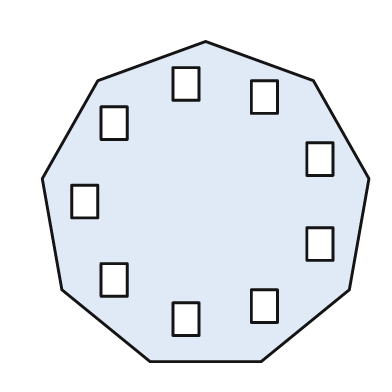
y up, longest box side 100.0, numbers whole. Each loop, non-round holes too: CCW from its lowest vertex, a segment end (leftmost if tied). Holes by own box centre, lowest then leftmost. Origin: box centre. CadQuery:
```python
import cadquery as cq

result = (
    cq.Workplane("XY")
    .moveTo(-17.0, -49.0)
    .lineTo(17.0, -49.0)
    .lineTo(44.0, -27.0)
    .lineTo(50.0, 7.0)
    .lineTo(33.0, 37.0)
    .lineTo(0.0, 49.0)
    .lineTo(-33.0, 37.0)
    .lineTo(-50.0, 7.0)
    .lineTo(-44.0, -27.0)
    .close()
    .moveTo(-10.0, -41.0)
    .lineTo(-2.0, -41.0)
    .lineTo(-2.0, -31.0)
    .lineTo(-10.0, -31.0)
    .close()
    .moveTo(14.0, -37.0)
    .lineTo(22.0, -37.0)
    .lineTo(22.0, -27.0)
    .lineTo(14.0, -27.0)
    .close()
    .moveTo(-32.0, -29.0)
    .lineTo(-24.0, -29.0)
    .lineTo(-24.0, -19.0)
    .lineTo(-32.0, -19.0)
    .close()
    .moveTo(31.0, -18.0)
    .lineTo(39.0, -18.0)
    .lineTo(39.0, -8.0)
    .lineTo(31.0, -8.0)
    .close()
    .moveTo(-41.0, -5.0)
    .lineTo(-33.0, -5.0)
    .lineTo(-33.0, 5.0)
    .lineTo(-41.0, 5.0)
    .close()
    .moveTo(31.0, 8.0)
    .lineTo(39.0, 8.0)
    .lineTo(39.0, 18.0)
    .lineTo(31.0, 18.0)
    .close()
    .moveTo(-32.0, 19.0)
    .lineTo(-24.0, 19.0)
    .lineTo(-24.0, 29.0)
    .lineTo(-32.0, 29.0)
    .close()
    .moveTo(14.0, 27.0)
    .lineTo(22.0, 27.0)
    .lineTo(22.0, 37.0)
    .lineTo(14.0, 37.0)
    .close()
    .moveTo(-10.0, 31.0)
    .lineTo(-2.0, 31.0)
    .lineTo(-2.0, 41.0)
    .lineTo(-10.0, 41.0)
    .close()
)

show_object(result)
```